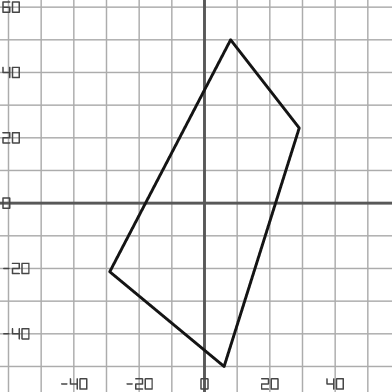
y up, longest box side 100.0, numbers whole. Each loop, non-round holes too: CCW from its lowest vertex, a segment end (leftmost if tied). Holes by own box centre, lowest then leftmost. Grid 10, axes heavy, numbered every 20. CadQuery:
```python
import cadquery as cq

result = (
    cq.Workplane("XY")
    .moveTo(6.0, -50.0)
    .lineTo(29.0, 23.0)
    .lineTo(8.0, 50.0)
    .lineTo(-29.0, -21.0)
    .close()
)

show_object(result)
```